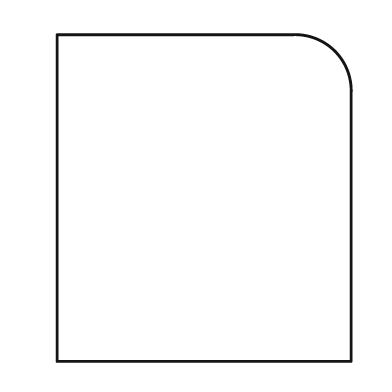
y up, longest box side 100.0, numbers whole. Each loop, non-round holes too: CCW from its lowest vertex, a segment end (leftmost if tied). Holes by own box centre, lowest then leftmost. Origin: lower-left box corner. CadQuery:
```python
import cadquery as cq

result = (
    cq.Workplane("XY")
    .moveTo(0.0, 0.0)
    .lineTo(90.0, 0.0)
    .lineTo(90.0, 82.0)
    .threePointArc((85.0, 95.0), (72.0, 100.0))
    .lineTo(0.0, 100.0)
    .close()
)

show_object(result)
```